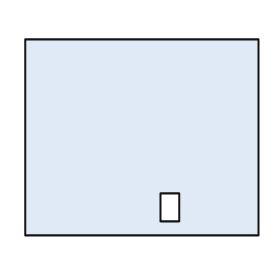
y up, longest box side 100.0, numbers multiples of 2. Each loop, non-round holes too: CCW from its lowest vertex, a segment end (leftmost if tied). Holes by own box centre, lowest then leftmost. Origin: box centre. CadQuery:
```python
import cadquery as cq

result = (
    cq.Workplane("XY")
    .moveTo(-50.0, -42.0)
    .lineTo(50.0, -42.0)
    .lineTo(50.0, 42.0)
    .lineTo(-50.0, 42.0)
    .close()
    .moveTo(8.0, -36.0)
    .lineTo(16.0, -36.0)
    .lineTo(16.0, -24.0)
    .lineTo(8.0, -24.0)
    .close()
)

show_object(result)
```